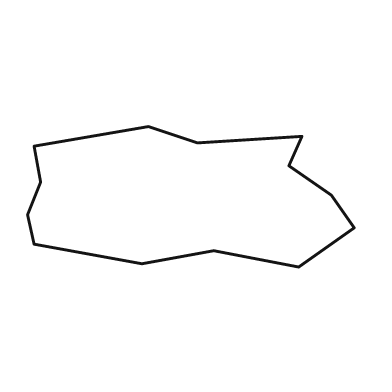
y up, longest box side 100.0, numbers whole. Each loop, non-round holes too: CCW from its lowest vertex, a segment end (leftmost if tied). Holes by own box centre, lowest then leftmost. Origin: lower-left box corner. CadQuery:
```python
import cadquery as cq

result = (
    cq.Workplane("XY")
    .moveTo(83.0, 0.0)
    .lineTo(100.0, 12.0)
    .lineTo(93.0, 22.0)
    .lineTo(80.0, 31.0)
    .lineTo(84.0, 40.0)
    .lineTo(52.0, 38.0)
    .lineTo(37.0, 43.0)
    .lineTo(2.0, 37.0)
    .lineTo(4.0, 26.0)
    .lineTo(0.0, 16.0)
    .lineTo(2.0, 7.0)
    .lineTo(35.0, 1.0)
    .lineTo(57.0, 5.0)
    .close()
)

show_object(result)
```